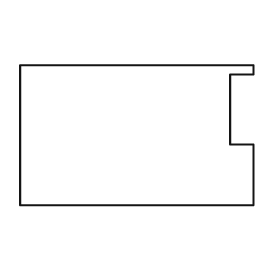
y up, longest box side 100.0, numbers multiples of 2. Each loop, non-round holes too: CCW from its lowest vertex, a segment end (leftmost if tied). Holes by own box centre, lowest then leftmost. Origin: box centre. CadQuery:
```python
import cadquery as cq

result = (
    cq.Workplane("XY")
    .moveTo(-50.0, -30.0)
    .lineTo(50.0, -30.0)
    .lineTo(50.0, -4.0)
    .lineTo(40.0, -4.0)
    .lineTo(40.0, 26.0)
    .lineTo(50.0, 26.0)
    .lineTo(50.0, 30.0)
    .lineTo(-50.0, 30.0)
    .close()
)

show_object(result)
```